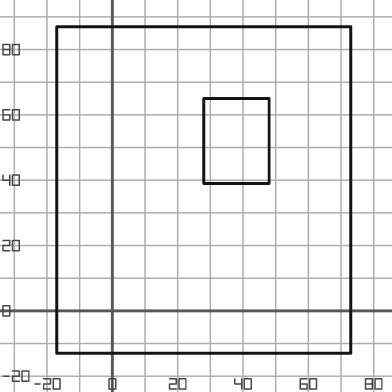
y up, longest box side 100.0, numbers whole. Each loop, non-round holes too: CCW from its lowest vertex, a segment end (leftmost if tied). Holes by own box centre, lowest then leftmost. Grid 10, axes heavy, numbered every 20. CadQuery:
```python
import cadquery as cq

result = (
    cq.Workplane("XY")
    .moveTo(-17.0, -13.0)
    .lineTo(73.0, -13.0)
    .lineTo(73.0, 87.0)
    .lineTo(-17.0, 87.0)
    .close()
    .moveTo(28.0, 39.0)
    .lineTo(48.0, 39.0)
    .lineTo(48.0, 65.0)
    .lineTo(28.0, 65.0)
    .close()
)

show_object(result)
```